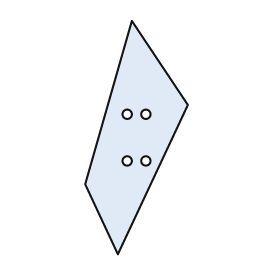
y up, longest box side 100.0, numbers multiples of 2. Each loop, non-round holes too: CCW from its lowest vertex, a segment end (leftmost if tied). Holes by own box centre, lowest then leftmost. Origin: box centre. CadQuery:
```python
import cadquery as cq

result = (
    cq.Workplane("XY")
    .moveTo(-8.0, -50.0)
    .lineTo(22.0, 14.0)
    .lineTo(-2.0, 50.0)
    .lineTo(-22.0, -20.0)
    .close()
    .moveTo(-4.0, -10.0)
    .circle(2.0)
    .moveTo(4.0, -10.0)
    .circle(2.0)
    .moveTo(-4.0, 10.0)
    .circle(2.0)
    .moveTo(4.0, 10.0)
    .circle(2.0)
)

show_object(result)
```